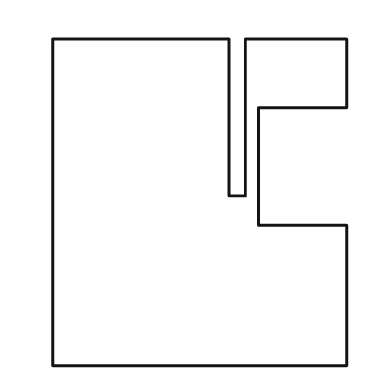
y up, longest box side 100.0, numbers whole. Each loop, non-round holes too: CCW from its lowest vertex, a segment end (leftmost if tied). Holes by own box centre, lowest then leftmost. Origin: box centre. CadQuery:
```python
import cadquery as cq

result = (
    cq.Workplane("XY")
    .moveTo(-45.0, -50.0)
    .lineTo(45.0, -50.0)
    .lineTo(45.0, -7.0)
    .lineTo(18.0, -7.0)
    .lineTo(18.0, 29.0)
    .lineTo(45.0, 29.0)
    .lineTo(45.0, 50.0)
    .lineTo(14.0, 50.0)
    .lineTo(14.0, 2.0)
    .lineTo(9.0, 2.0)
    .lineTo(9.0, 50.0)
    .lineTo(-45.0, 50.0)
    .close()
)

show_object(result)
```